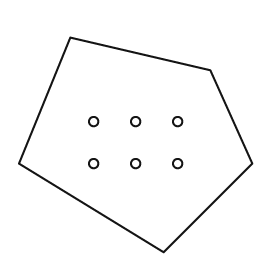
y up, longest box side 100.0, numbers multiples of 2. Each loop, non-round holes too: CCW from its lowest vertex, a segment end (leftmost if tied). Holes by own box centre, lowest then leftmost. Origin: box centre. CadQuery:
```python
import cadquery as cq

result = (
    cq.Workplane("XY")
    .moveTo(12.0, -46.0)
    .lineTo(50.0, -8.0)
    .lineTo(32.0, 32.0)
    .lineTo(-28.0, 46.0)
    .lineTo(-50.0, -8.0)
    .close()
    .moveTo(-18.0, -8.0)
    .circle(2.0)
    .moveTo(0.0, -8.0)
    .circle(2.0)
    .moveTo(18.0, -8.0)
    .circle(2.0)
    .moveTo(-18.0, 10.0)
    .circle(2.0)
    .moveTo(0.0, 10.0)
    .circle(2.0)
    .moveTo(18.0, 10.0)
    .circle(2.0)
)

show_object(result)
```